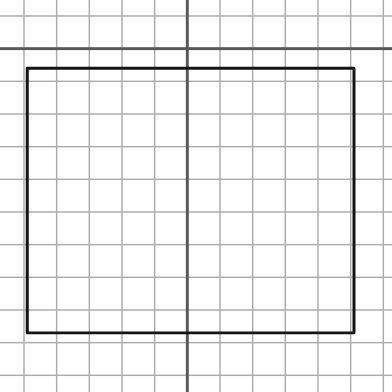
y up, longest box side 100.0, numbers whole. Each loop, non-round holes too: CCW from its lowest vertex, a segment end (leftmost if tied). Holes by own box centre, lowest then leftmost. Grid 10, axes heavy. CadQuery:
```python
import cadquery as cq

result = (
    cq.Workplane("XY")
    .moveTo(-49.0, -87.0)
    .lineTo(51.0, -87.0)
    .lineTo(51.0, -6.0)
    .lineTo(-49.0, -6.0)
    .close()
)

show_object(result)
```